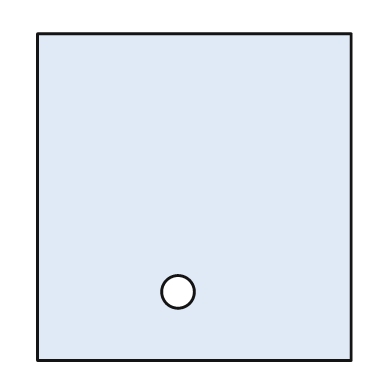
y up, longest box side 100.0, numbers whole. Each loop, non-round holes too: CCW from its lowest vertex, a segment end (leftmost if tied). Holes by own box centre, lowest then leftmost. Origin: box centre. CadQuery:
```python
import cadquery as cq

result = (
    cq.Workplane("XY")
    .moveTo(-48.0, -50.0)
    .lineTo(48.0, -50.0)
    .lineTo(48.0, 50.0)
    .lineTo(-48.0, 50.0)
    .close()
    .moveTo(-5.0, -29.0)
    .circle(5.0)
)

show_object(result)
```